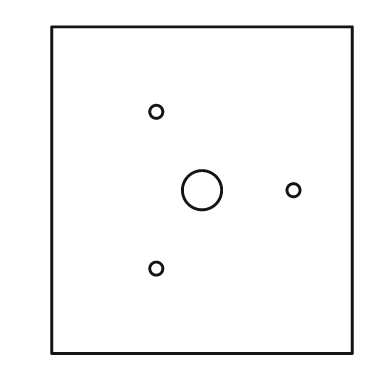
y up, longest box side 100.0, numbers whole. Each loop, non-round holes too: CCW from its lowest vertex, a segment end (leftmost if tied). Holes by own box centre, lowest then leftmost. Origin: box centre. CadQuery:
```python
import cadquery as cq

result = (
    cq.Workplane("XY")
    .moveTo(-46.0, -50.0)
    .lineTo(46.0, -50.0)
    .lineTo(46.0, 50.0)
    .lineTo(-46.0, 50.0)
    .close()
    .moveTo(-14.0, -24.0)
    .circle(2.0)
    .moveTo(0.0, 0.0)
    .circle(6.0)
    .moveTo(28.0, 0.0)
    .circle(2.0)
    .moveTo(-14.0, 24.0)
    .circle(2.0)
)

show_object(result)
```